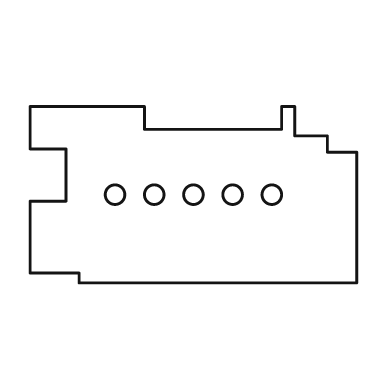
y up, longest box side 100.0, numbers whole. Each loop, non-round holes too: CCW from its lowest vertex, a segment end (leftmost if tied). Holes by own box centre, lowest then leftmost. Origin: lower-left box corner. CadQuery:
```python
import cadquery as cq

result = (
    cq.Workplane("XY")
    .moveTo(15.0, 0.0)
    .lineTo(100.0, 0.0)
    .lineTo(100.0, 40.0)
    .lineTo(91.0, 40.0)
    .lineTo(91.0, 45.0)
    .lineTo(81.0, 45.0)
    .lineTo(81.0, 54.0)
    .lineTo(77.0, 54.0)
    .lineTo(77.0, 47.0)
    .lineTo(35.0, 47.0)
    .lineTo(35.0, 54.0)
    .lineTo(0.0, 54.0)
    .lineTo(0.0, 41.0)
    .lineTo(11.0, 41.0)
    .lineTo(11.0, 25.0)
    .lineTo(0.0, 25.0)
    .lineTo(0.0, 3.0)
    .lineTo(15.0, 3.0)
    .close()
    .moveTo(26.0, 27.0)
    .circle(3.0)
    .moveTo(38.0, 27.0)
    .circle(3.0)
    .moveTo(50.0, 27.0)
    .circle(3.0)
    .moveTo(62.0, 27.0)
    .circle(3.0)
    .moveTo(74.0, 27.0)
    .circle(3.0)
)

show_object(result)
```